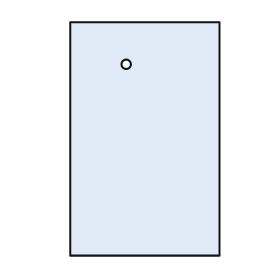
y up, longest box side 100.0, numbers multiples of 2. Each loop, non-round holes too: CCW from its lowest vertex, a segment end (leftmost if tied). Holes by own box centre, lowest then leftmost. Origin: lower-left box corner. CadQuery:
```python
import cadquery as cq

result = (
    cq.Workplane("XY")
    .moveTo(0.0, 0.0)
    .lineTo(64.0, 0.0)
    .lineTo(64.0, 100.0)
    .lineTo(0.0, 100.0)
    .close()
    .moveTo(24.0, 82.0)
    .circle(2.0)
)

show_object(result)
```